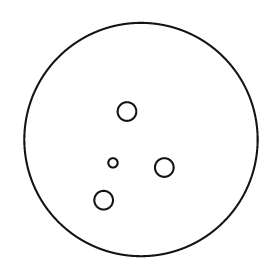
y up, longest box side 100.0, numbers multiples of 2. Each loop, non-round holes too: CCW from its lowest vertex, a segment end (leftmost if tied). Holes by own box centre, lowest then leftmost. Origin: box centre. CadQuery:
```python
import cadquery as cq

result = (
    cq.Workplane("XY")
    .moveTo(0.0, 0.0)
    .circle(50.0)
    .moveTo(-16.0, -26.0)
    .circle(4.0)
    .moveTo(10.0, -12.0)
    .circle(4.0)
    .moveTo(-12.0, -10.0)
    .circle(2.0)
    .moveTo(-6.0, 12.0)
    .circle(4.0)
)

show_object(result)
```